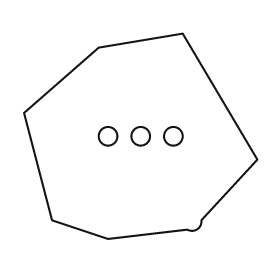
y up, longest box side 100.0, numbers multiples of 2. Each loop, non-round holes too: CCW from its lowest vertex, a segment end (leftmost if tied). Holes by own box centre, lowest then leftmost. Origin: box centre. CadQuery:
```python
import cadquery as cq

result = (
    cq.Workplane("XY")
    .moveTo(-14.0, -44.0)
    .lineTo(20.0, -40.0)
    .threePointArc((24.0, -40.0), (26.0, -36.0))
    .lineTo(50.0, -10.0)
    .lineTo(18.0, 44.0)
    .lineTo(-18.0, 38.0)
    .lineTo(-50.0, 10.0)
    .lineTo(-38.0, -36.0)
    .close()
    .moveTo(-14.0, 0.0)
    .circle(4.0)
    .moveTo(0.0, 0.0)
    .circle(4.0)
    .moveTo(14.0, 0.0)
    .circle(4.0)
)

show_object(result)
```